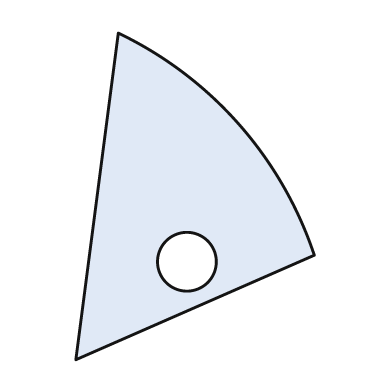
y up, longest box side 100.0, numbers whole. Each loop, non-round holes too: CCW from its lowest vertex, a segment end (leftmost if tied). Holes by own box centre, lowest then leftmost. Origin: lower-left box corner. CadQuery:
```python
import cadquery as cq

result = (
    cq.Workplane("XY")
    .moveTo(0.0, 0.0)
    .lineTo(73.0, 32.0)
    .threePointArc((50.0, 72.0), (13.0, 100.0))
    .close()
    .moveTo(34.0, 30.0)
    .circle(9.0)
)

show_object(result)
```